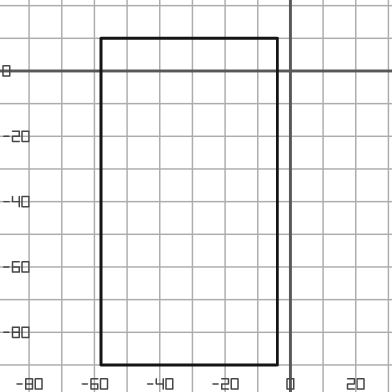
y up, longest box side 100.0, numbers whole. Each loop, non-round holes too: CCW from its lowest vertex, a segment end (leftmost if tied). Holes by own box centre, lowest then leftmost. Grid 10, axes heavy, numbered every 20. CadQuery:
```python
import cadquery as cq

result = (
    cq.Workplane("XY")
    .moveTo(-58.0, -90.0)
    .lineTo(-4.0, -90.0)
    .lineTo(-4.0, 10.0)
    .lineTo(-58.0, 10.0)
    .close()
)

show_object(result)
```